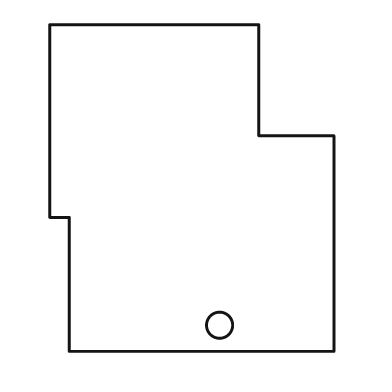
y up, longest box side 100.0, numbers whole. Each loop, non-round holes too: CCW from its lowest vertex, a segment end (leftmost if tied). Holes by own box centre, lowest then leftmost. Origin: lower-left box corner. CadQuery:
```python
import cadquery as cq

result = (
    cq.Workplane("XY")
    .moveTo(6.0, 0.0)
    .lineTo(87.0, 0.0)
    .lineTo(87.0, 66.0)
    .lineTo(64.0, 66.0)
    .lineTo(64.0, 100.0)
    .lineTo(0.0, 100.0)
    .lineTo(0.0, 41.0)
    .lineTo(6.0, 41.0)
    .close()
    .moveTo(52.0, 8.0)
    .circle(4.0)
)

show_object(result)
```